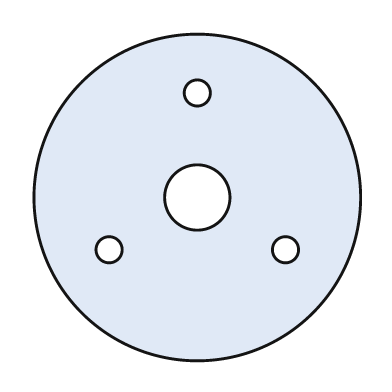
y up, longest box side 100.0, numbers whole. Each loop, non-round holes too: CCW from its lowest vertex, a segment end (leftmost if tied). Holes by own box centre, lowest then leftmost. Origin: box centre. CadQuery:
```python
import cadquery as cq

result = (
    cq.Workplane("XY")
    .moveTo(0.0, 0.0)
    .circle(50.0)
    .moveTo(-27.0, -16.0)
    .circle(4.0)
    .moveTo(27.0, -16.0)
    .circle(4.0)
    .moveTo(0.0, 0.0)
    .circle(10.0)
    .moveTo(0.0, 32.0)
    .circle(4.0)
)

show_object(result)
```